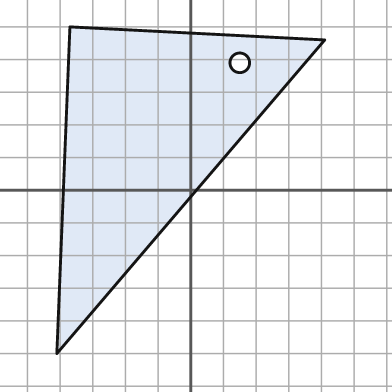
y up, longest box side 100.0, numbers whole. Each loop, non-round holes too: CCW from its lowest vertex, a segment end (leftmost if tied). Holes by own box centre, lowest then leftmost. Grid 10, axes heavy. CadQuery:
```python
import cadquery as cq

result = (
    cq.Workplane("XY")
    .moveTo(-41.0, -50.0)
    .lineTo(41.0, 46.0)
    .lineTo(-37.0, 50.0)
    .close()
    .moveTo(15.0, 39.0)
    .circle(3.0)
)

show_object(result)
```